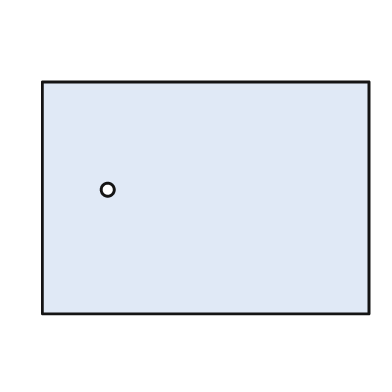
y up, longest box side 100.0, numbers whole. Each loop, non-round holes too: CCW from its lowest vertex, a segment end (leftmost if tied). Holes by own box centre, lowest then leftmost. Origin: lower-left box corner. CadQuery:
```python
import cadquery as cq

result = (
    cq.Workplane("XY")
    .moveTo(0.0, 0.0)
    .lineTo(100.0, 0.0)
    .lineTo(100.0, 71.0)
    .lineTo(0.0, 71.0)
    .close()
    .moveTo(20.0, 38.0)
    .circle(2.0)
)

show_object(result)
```